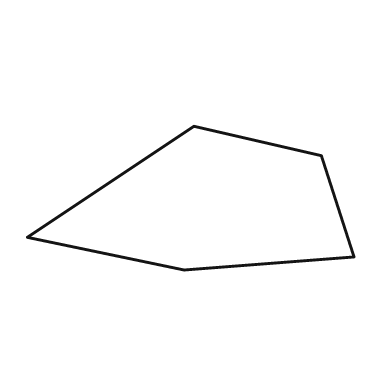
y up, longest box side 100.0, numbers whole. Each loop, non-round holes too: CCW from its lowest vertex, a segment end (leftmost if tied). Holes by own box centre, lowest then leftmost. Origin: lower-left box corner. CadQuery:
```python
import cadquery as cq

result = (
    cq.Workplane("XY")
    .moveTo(48.0, 0.0)
    .lineTo(100.0, 4.0)
    .lineTo(90.0, 35.0)
    .lineTo(51.0, 44.0)
    .lineTo(0.0, 10.0)
    .close()
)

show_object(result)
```